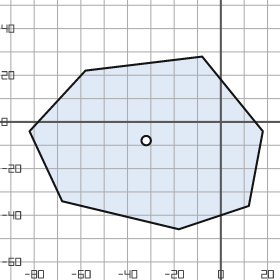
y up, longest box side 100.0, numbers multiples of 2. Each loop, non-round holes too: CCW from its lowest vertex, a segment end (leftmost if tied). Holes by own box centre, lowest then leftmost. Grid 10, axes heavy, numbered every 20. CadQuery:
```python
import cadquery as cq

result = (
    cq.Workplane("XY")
    .moveTo(-18.0, -46.0)
    .lineTo(12.0, -36.0)
    .lineTo(18.0, -4.0)
    .lineTo(-8.0, 28.0)
    .lineTo(-58.0, 22.0)
    .lineTo(-82.0, -4.0)
    .lineTo(-68.0, -34.0)
    .close()
    .moveTo(-32.0, -8.0)
    .circle(2.0)
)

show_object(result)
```